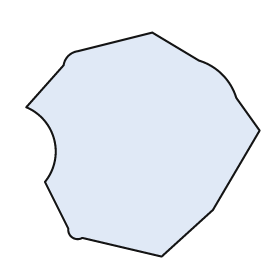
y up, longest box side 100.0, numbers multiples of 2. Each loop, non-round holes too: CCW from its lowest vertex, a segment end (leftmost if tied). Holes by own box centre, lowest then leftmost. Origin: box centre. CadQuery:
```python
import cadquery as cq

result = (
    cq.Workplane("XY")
    .moveTo(8.0, -48.0)
    .lineTo(30.0, -28.0)
    .lineTo(50.0, 6.0)
    .lineTo(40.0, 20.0)
    .threePointArc((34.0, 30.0), (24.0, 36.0))
    .lineTo(4.0, 48.0)
    .lineTo(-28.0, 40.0)
    .threePointArc((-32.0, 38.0), (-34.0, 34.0))
    .lineTo(-50.0, 16.0)
    .threePointArc((-38.0, 2.0), (-42.0, -16.0))
    .lineTo(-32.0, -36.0)
    .threePointArc((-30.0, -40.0), (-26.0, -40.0))
    .close()
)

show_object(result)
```